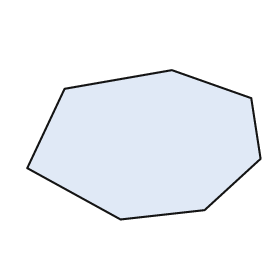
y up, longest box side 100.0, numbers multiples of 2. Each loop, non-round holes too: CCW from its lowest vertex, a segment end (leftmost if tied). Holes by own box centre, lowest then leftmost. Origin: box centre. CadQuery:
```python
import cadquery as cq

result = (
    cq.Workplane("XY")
    .moveTo(-10.0, -32.0)
    .lineTo(26.0, -28.0)
    .lineTo(50.0, -6.0)
    .lineTo(46.0, 20.0)
    .lineTo(12.0, 32.0)
    .lineTo(-34.0, 24.0)
    .lineTo(-50.0, -10.0)
    .close()
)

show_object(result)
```